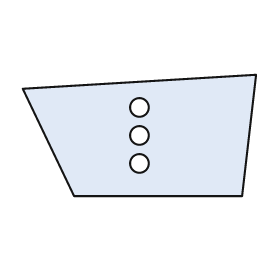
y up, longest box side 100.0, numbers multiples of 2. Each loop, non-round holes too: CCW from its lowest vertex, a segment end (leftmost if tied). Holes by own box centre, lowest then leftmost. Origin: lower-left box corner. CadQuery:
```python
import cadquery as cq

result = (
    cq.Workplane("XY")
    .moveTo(22.0, 0.0)
    .lineTo(94.0, 0.0)
    .lineTo(100.0, 52.0)
    .lineTo(0.0, 46.0)
    .close()
    .moveTo(50.0, 14.0)
    .circle(4.0)
    .moveTo(50.0, 26.0)
    .circle(4.0)
    .moveTo(50.0, 38.0)
    .circle(4.0)
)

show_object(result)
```